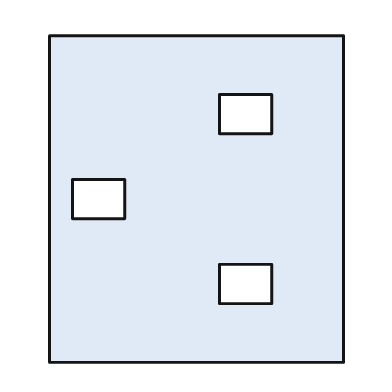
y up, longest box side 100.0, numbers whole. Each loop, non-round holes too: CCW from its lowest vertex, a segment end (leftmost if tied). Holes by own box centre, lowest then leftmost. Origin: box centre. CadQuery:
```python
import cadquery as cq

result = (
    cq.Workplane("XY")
    .moveTo(-45.0, -50.0)
    .lineTo(45.0, -50.0)
    .lineTo(45.0, 50.0)
    .lineTo(-45.0, 50.0)
    .close()
    .moveTo(7.0, -32.0)
    .lineTo(23.0, -32.0)
    .lineTo(23.0, -20.0)
    .lineTo(7.0, -20.0)
    .close()
    .moveTo(-38.0, -6.0)
    .lineTo(-22.0, -6.0)
    .lineTo(-22.0, 6.0)
    .lineTo(-38.0, 6.0)
    .close()
    .moveTo(7.0, 20.0)
    .lineTo(23.0, 20.0)
    .lineTo(23.0, 32.0)
    .lineTo(7.0, 32.0)
    .close()
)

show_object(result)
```